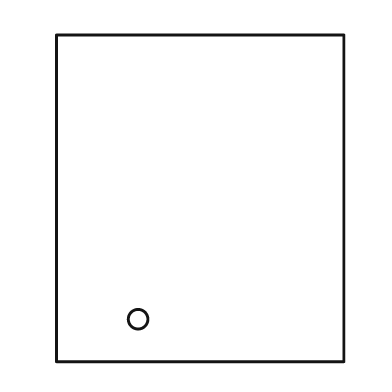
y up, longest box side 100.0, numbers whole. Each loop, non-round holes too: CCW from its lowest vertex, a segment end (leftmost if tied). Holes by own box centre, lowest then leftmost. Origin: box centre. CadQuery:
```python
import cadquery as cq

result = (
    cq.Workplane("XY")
    .moveTo(-44.0, -50.0)
    .lineTo(44.0, -50.0)
    .lineTo(44.0, 50.0)
    .lineTo(-44.0, 50.0)
    .close()
    .moveTo(-19.0, -37.0)
    .circle(3.0)
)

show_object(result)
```